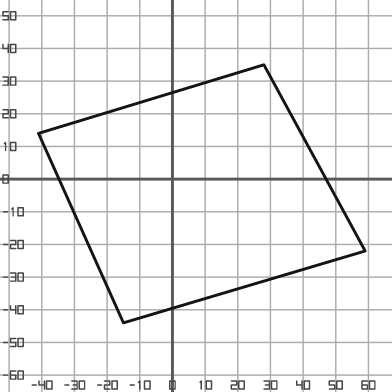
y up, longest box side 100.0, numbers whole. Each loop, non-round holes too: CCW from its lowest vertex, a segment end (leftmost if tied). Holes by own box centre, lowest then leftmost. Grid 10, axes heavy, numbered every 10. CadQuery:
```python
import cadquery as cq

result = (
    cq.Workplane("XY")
    .moveTo(-15.0, -44.0)
    .lineTo(59.0, -22.0)
    .lineTo(28.0, 35.0)
    .lineTo(-41.0, 14.0)
    .close()
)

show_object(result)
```